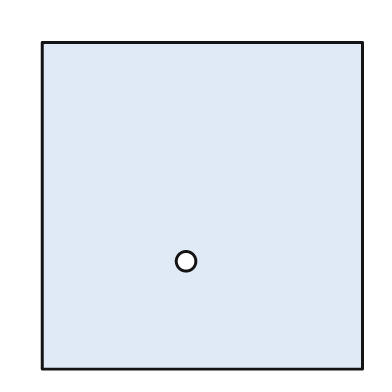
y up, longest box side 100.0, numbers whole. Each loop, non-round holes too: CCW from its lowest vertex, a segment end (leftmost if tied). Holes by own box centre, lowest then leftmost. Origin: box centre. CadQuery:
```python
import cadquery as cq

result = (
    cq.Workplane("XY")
    .moveTo(-49.0, -50.0)
    .lineTo(49.0, -50.0)
    .lineTo(49.0, 50.0)
    .lineTo(-49.0, 50.0)
    .close()
    .moveTo(-5.0, -17.0)
    .circle(3.0)
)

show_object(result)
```